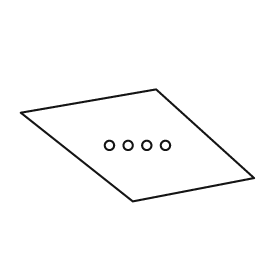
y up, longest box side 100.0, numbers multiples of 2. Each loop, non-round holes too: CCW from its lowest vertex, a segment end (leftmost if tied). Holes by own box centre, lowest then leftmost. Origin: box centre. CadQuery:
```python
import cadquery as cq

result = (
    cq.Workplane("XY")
    .moveTo(-2.0, -24.0)
    .lineTo(50.0, -14.0)
    .lineTo(8.0, 24.0)
    .lineTo(-50.0, 14.0)
    .close()
    .moveTo(-12.0, 0.0)
    .circle(2.0)
    .moveTo(-4.0, 0.0)
    .circle(2.0)
    .moveTo(4.0, 0.0)
    .circle(2.0)
    .moveTo(12.0, 0.0)
    .circle(2.0)
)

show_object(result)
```